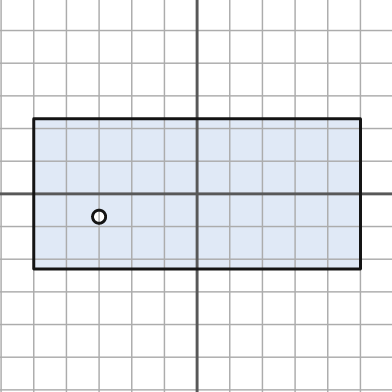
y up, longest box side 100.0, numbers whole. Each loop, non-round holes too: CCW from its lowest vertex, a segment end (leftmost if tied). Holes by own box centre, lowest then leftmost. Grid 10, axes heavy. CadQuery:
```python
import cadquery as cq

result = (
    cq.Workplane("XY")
    .moveTo(-50.0, -23.0)
    .lineTo(50.0, -23.0)
    .lineTo(50.0, 23.0)
    .lineTo(-50.0, 23.0)
    .close()
    .moveTo(-30.0, -7.0)
    .circle(2.0)
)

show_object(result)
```